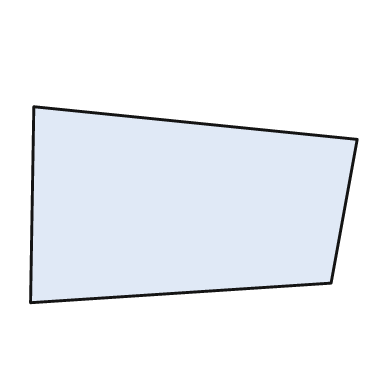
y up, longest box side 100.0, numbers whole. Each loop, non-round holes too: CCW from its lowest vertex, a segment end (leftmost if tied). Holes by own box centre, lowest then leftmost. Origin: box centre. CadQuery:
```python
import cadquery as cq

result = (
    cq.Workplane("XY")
    .moveTo(-50.0, -30.0)
    .lineTo(42.0, -24.0)
    .lineTo(50.0, 20.0)
    .lineTo(-49.0, 30.0)
    .close()
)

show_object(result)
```